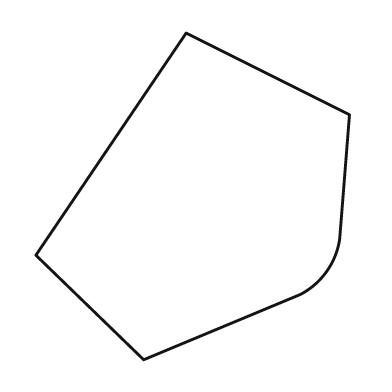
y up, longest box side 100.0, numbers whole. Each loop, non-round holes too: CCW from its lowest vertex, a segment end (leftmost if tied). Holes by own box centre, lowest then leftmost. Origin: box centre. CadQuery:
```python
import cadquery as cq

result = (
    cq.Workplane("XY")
    .moveTo(-15.0, -50.0)
    .lineTo(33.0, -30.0)
    .threePointArc((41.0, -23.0), (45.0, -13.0))
    .lineTo(48.0, 25.0)
    .lineTo(-2.0, 50.0)
    .lineTo(-48.0, -18.0)
    .close()
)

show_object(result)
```